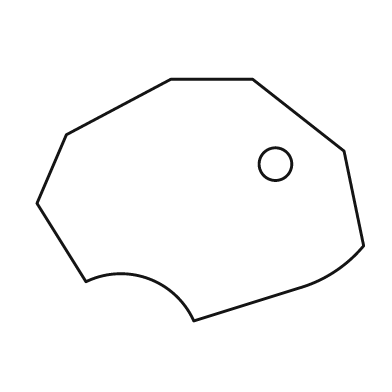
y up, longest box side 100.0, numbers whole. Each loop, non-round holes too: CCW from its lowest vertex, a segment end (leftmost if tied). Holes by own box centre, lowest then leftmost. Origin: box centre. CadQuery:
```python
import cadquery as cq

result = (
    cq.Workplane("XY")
    .moveTo(-2.0, -37.0)
    .lineTo(30.0, -27.0)
    .threePointArc((41.0, -22.0), (50.0, -14.0))
    .lineTo(44.0, 15.0)
    .lineTo(16.0, 37.0)
    .lineTo(-9.0, 37.0)
    .lineTo(-41.0, 20.0)
    .lineTo(-50.0, -1.0)
    .lineTo(-35.0, -25.0)
    .threePointArc((-16.0, -24.0), (-2.0, -37.0))
    .close()
    .moveTo(23.0, 11.0)
    .circle(5.0)
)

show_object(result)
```